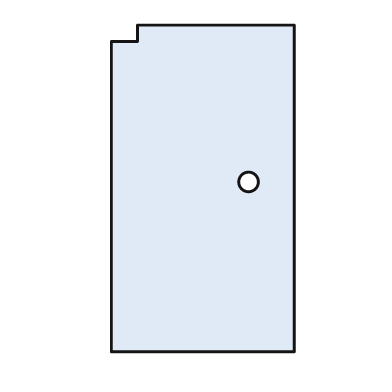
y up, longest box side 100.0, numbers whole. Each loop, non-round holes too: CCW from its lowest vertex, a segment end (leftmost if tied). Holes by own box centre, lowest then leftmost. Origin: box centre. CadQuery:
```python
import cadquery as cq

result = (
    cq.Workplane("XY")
    .moveTo(-28.0, -50.0)
    .lineTo(28.0, -50.0)
    .lineTo(28.0, 50.0)
    .lineTo(-20.0, 50.0)
    .lineTo(-20.0, 45.0)
    .lineTo(-28.0, 45.0)
    .close()
    .moveTo(14.0, 2.0)
    .circle(3.0)
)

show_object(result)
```